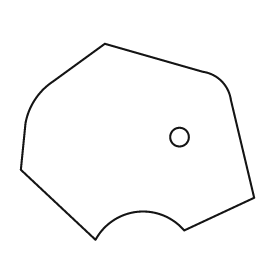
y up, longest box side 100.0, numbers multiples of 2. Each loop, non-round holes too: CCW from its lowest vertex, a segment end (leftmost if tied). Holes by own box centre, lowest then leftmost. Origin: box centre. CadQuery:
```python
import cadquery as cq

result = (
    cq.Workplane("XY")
    .moveTo(-18.0, -42.0)
    .threePointArc((0.0, -30.0), (20.0, -38.0))
    .lineTo(50.0, -24.0)
    .lineTo(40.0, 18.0)
    .threePointArc((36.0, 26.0), (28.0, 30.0))
    .lineTo(-14.0, 42.0)
    .lineTo(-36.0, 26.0)
    .threePointArc((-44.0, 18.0), (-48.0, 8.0))
    .lineTo(-50.0, -12.0)
    .close()
    .moveTo(18.0, 2.0)
    .circle(4.0)
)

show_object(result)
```